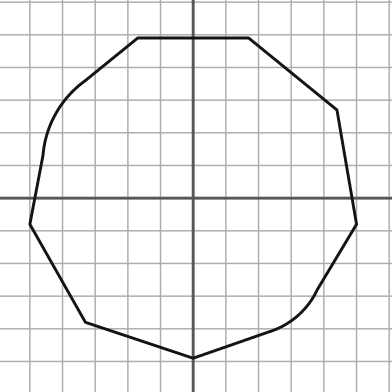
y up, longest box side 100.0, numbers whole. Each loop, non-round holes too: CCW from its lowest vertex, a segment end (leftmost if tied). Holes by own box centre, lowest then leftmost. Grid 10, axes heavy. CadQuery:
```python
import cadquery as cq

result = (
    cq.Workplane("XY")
    .moveTo(0.0, -49.0)
    .lineTo(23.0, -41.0)
    .threePointArc((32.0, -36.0), (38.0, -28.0))
    .lineTo(50.0, -8.0)
    .lineTo(44.0, 27.0)
    .lineTo(17.0, 49.0)
    .lineTo(-17.0, 49.0)
    .lineTo(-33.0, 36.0)
    .threePointArc((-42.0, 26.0), (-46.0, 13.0))
    .lineTo(-50.0, -8.0)
    .lineTo(-33.0, -38.0)
    .close()
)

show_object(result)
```